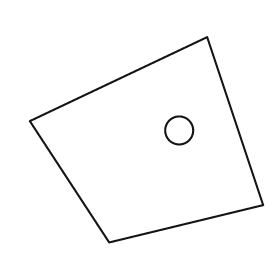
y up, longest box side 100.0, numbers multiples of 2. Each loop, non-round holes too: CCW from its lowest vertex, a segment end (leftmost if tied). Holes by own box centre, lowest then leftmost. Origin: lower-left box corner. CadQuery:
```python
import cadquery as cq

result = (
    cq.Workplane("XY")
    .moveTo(34.0, 0.0)
    .lineTo(100.0, 16.0)
    .lineTo(76.0, 88.0)
    .lineTo(0.0, 52.0)
    .close()
    .moveTo(64.0, 48.0)
    .circle(6.0)
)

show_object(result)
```